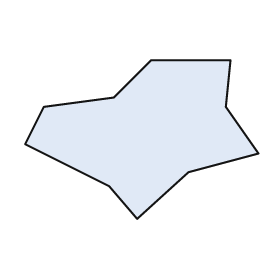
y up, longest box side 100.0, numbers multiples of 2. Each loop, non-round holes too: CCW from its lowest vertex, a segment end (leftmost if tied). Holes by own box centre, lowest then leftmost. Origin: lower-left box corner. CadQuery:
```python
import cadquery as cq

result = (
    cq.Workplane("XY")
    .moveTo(48.0, 0.0)
    .lineTo(70.0, 20.0)
    .lineTo(100.0, 28.0)
    .lineTo(86.0, 48.0)
    .lineTo(88.0, 68.0)
    .lineTo(54.0, 68.0)
    .lineTo(38.0, 52.0)
    .lineTo(8.0, 48.0)
    .lineTo(0.0, 32.0)
    .lineTo(36.0, 14.0)
    .close()
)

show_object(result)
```